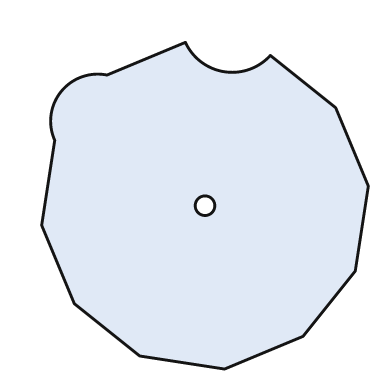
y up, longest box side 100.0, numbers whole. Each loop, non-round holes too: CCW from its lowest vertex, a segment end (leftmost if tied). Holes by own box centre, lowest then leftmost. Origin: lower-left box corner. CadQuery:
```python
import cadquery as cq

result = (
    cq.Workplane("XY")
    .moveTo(56.0, 0.0)
    .lineTo(80.0, 10.0)
    .lineTo(96.0, 30.0)
    .lineTo(100.0, 56.0)
    .lineTo(90.0, 80.0)
    .lineTo(70.0, 96.0)
    .threePointArc((56.0, 91.0), (44.0, 100.0))
    .lineTo(20.0, 90.0)
    .threePointArc((6.0, 85.0), (4.0, 70.0))
    .lineTo(0.0, 44.0)
    .lineTo(10.0, 20.0)
    .lineTo(30.0, 4.0)
    .close()
    .moveTo(50.0, 50.0)
    .circle(3.0)
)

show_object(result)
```